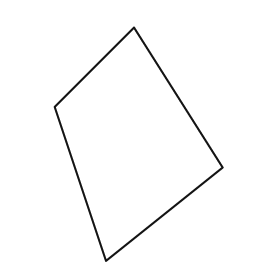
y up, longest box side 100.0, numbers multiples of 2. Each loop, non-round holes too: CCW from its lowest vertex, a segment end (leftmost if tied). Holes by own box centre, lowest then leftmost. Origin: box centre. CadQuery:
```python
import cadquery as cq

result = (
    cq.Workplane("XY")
    .moveTo(-14.0, -50.0)
    .lineTo(36.0, -10.0)
    .lineTo(-2.0, 50.0)
    .lineTo(-36.0, 16.0)
    .close()
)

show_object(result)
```